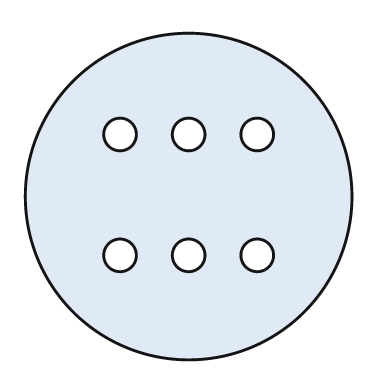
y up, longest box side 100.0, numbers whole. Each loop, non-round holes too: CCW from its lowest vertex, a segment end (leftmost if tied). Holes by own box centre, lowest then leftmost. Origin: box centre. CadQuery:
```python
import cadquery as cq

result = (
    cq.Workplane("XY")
    .moveTo(0.0, 0.0)
    .circle(50.0)
    .moveTo(-21.0, -18.0)
    .circle(5.0)
    .moveTo(0.0, -18.0)
    .circle(5.0)
    .moveTo(21.0, -18.0)
    .circle(5.0)
    .moveTo(-21.0, 19.0)
    .circle(5.0)
    .moveTo(0.0, 19.0)
    .circle(5.0)
    .moveTo(21.0, 19.0)
    .circle(5.0)
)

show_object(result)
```